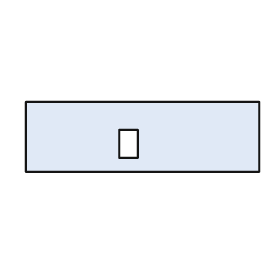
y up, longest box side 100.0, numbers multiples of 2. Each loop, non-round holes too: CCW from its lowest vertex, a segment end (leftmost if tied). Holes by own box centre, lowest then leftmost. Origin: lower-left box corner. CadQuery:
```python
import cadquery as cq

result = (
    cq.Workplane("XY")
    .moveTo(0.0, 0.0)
    .lineTo(100.0, 0.0)
    .lineTo(100.0, 30.0)
    .lineTo(0.0, 30.0)
    .close()
    .moveTo(40.0, 6.0)
    .lineTo(48.0, 6.0)
    .lineTo(48.0, 18.0)
    .lineTo(40.0, 18.0)
    .close()
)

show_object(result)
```